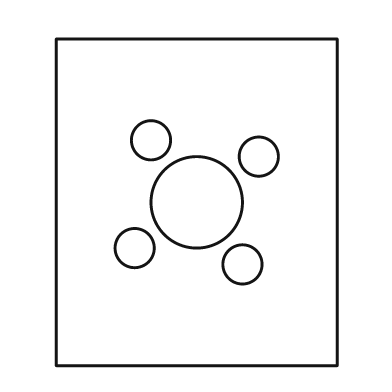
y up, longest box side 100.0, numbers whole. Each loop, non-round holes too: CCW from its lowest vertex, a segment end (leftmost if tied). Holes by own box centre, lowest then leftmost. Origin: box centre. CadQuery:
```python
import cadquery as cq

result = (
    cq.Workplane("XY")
    .moveTo(-43.0, -50.0)
    .lineTo(43.0, -50.0)
    .lineTo(43.0, 50.0)
    .lineTo(-43.0, 50.0)
    .close()
    .moveTo(14.0, -19.0)
    .circle(6.0)
    .moveTo(-19.0, -14.0)
    .circle(6.0)
    .moveTo(0.0, 0.0)
    .circle(14.0)
    .moveTo(19.0, 14.0)
    .circle(6.0)
    .moveTo(-14.0, 19.0)
    .circle(6.0)
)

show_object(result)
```